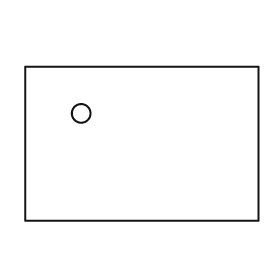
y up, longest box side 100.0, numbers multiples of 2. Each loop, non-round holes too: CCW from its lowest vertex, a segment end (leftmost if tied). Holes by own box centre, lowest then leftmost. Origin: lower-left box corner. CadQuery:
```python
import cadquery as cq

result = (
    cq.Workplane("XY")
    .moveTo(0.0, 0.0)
    .lineTo(100.0, 0.0)
    .lineTo(100.0, 66.0)
    .lineTo(0.0, 66.0)
    .close()
    .moveTo(24.0, 46.0)
    .circle(4.0)
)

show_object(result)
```